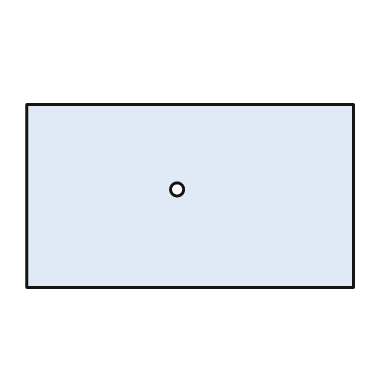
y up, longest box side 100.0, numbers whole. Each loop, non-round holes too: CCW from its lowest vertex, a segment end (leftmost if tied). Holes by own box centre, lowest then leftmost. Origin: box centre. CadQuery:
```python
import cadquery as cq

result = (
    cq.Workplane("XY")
    .moveTo(-50.0, -28.0)
    .lineTo(50.0, -28.0)
    .lineTo(50.0, 28.0)
    .lineTo(-50.0, 28.0)
    .close()
    .moveTo(-4.0, 2.0)
    .circle(2.0)
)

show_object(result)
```